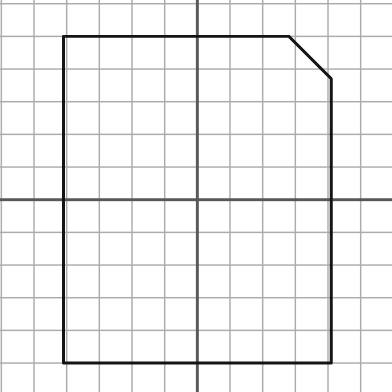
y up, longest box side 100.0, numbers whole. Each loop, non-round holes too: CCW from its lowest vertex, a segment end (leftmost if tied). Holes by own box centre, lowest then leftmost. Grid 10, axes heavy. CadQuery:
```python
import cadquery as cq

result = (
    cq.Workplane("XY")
    .moveTo(-41.0, -50.0)
    .lineTo(41.0, -50.0)
    .lineTo(41.0, 37.0)
    .lineTo(28.0, 50.0)
    .lineTo(-41.0, 50.0)
    .close()
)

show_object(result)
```